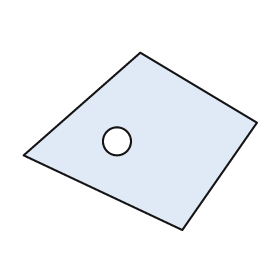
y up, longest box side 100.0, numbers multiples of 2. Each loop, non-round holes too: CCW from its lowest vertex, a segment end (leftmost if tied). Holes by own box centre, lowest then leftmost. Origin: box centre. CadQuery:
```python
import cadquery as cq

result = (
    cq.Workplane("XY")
    .moveTo(18.0, -38.0)
    .lineTo(50.0, 8.0)
    .lineTo(0.0, 38.0)
    .lineTo(-50.0, -6.0)
    .close()
    .moveTo(-10.0, 0.0)
    .circle(6.0)
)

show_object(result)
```